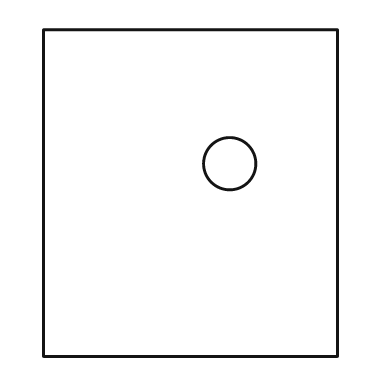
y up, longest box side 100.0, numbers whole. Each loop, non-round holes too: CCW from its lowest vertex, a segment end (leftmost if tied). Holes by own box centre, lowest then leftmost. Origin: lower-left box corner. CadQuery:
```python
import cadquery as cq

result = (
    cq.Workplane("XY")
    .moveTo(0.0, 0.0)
    .lineTo(90.0, 0.0)
    .lineTo(90.0, 100.0)
    .lineTo(0.0, 100.0)
    .close()
    .moveTo(57.0, 59.0)
    .circle(8.0)
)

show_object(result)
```